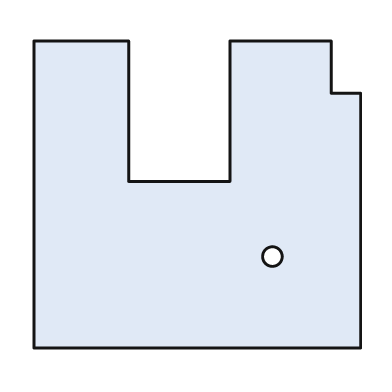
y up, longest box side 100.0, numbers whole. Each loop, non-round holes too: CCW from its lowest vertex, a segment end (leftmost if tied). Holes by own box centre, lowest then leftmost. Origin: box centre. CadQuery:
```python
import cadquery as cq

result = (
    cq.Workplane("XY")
    .moveTo(-50.0, -47.0)
    .lineTo(50.0, -47.0)
    .lineTo(50.0, 31.0)
    .lineTo(41.0, 31.0)
    .lineTo(41.0, 47.0)
    .lineTo(10.0, 47.0)
    .lineTo(10.0, 4.0)
    .lineTo(-21.0, 4.0)
    .lineTo(-21.0, 47.0)
    .lineTo(-50.0, 47.0)
    .close()
    .moveTo(23.0, -19.0)
    .circle(3.0)
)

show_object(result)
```